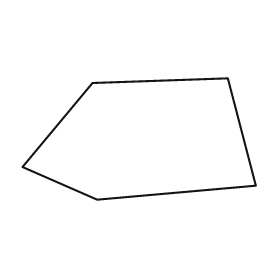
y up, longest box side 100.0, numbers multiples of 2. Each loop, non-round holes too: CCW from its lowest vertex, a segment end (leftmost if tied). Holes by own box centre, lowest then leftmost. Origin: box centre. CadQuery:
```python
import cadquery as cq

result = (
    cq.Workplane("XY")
    .moveTo(-18.0, -26.0)
    .lineTo(50.0, -20.0)
    .lineTo(38.0, 26.0)
    .lineTo(-20.0, 24.0)
    .lineTo(-50.0, -12.0)
    .close()
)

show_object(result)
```